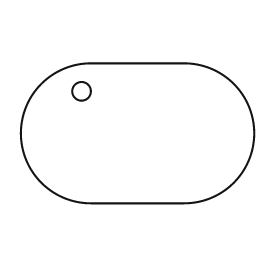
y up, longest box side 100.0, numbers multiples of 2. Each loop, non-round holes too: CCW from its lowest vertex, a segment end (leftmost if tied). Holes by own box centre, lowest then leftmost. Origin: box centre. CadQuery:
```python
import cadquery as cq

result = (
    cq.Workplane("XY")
    .moveTo(-20.0, -30.0)
    .lineTo(20.0, -30.0)
    .threePointArc((50.0, 0.0), (20.0, 30.0))
    .lineTo(-20.0, 30.0)
    .threePointArc((-50.0, 0.0), (-20.0, -30.0))
    .close()
    .moveTo(-24.0, 18.0)
    .circle(4.0)
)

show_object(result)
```